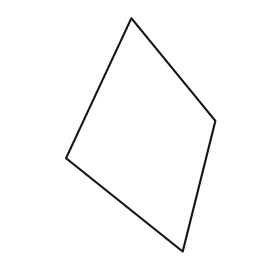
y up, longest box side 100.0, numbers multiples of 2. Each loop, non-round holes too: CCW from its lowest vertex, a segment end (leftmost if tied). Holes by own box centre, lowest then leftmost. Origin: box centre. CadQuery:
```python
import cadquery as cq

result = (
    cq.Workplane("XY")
    .moveTo(18.0, -50.0)
    .lineTo(32.0, 6.0)
    .lineTo(-4.0, 50.0)
    .lineTo(-32.0, -10.0)
    .close()
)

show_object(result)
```